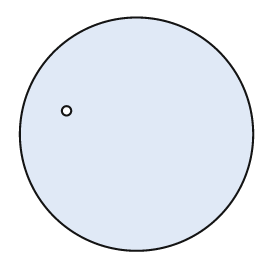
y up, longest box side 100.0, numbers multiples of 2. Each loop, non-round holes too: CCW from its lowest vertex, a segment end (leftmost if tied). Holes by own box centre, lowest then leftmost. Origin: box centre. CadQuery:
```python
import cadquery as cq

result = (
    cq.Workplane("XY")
    .moveTo(0.0, 0.0)
    .circle(50.0)
    .moveTo(-30.0, 10.0)
    .circle(2.0)
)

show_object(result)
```